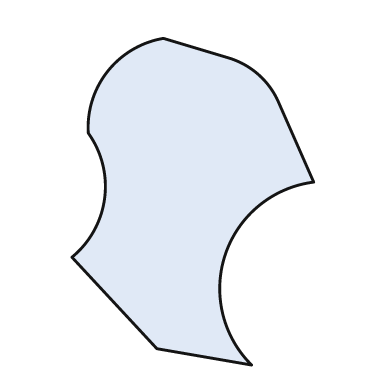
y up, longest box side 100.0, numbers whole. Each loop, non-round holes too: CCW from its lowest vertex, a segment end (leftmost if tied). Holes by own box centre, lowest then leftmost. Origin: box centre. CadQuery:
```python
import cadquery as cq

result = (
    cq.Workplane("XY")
    .moveTo(18.0, -50.0)
    .threePointArc((10.0, -16.0), (37.0, 6.0))
    .lineTo(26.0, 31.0)
    .threePointArc((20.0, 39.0), (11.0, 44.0))
    .lineTo(-9.0, 50.0)
    .threePointArc((-26.0, 40.0), (-32.0, 21.0))
    .threePointArc((-27.0, 1.0), (-37.0, -17.0))
    .lineTo(-11.0, -45.0)
    .close()
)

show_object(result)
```